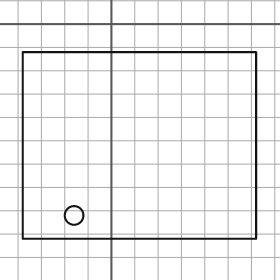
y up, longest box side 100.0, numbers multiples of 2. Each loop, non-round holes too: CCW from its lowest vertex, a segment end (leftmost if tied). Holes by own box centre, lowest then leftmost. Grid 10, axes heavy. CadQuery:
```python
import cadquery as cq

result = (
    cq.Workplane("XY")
    .moveTo(-38.0, -92.0)
    .lineTo(62.0, -92.0)
    .lineTo(62.0, -12.0)
    .lineTo(-38.0, -12.0)
    .close()
    .moveTo(-16.0, -82.0)
    .circle(4.0)
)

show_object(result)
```